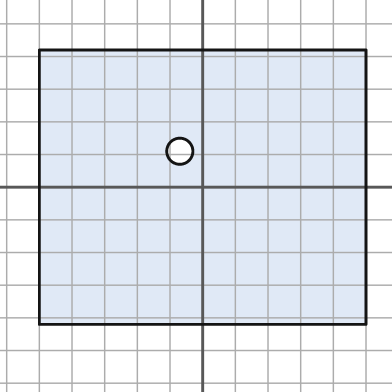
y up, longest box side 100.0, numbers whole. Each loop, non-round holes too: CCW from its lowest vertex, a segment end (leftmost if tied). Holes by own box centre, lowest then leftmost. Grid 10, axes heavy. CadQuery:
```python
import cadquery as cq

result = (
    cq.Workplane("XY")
    .moveTo(-50.0, -42.0)
    .lineTo(50.0, -42.0)
    .lineTo(50.0, 42.0)
    .lineTo(-50.0, 42.0)
    .close()
    .moveTo(-7.0, 11.0)
    .circle(4.0)
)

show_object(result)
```